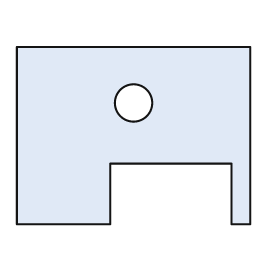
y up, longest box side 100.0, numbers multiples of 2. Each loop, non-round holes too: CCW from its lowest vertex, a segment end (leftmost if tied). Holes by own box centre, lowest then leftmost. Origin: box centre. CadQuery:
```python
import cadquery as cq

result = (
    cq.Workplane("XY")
    .moveTo(-50.0, -38.0)
    .lineTo(-10.0, -38.0)
    .lineTo(-10.0, -12.0)
    .lineTo(42.0, -12.0)
    .lineTo(42.0, -38.0)
    .lineTo(50.0, -38.0)
    .lineTo(50.0, 38.0)
    .lineTo(-50.0, 38.0)
    .close()
    .moveTo(0.0, 14.0)
    .circle(8.0)
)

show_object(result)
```